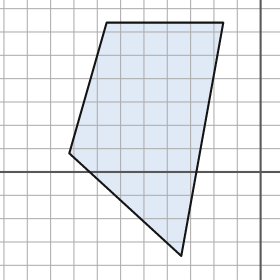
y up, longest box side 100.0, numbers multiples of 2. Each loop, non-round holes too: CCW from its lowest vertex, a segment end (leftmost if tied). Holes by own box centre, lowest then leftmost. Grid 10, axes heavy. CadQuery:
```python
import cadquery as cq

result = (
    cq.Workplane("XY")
    .moveTo(-34.0, -36.0)
    .lineTo(-16.0, 64.0)
    .lineTo(-66.0, 64.0)
    .lineTo(-82.0, 8.0)
    .close()
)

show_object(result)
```